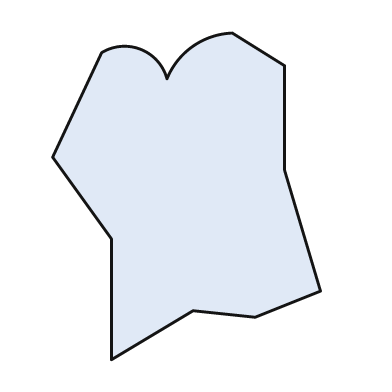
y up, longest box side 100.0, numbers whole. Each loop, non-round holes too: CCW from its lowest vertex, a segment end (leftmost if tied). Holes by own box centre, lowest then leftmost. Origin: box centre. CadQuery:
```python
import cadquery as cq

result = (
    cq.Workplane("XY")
    .moveTo(-23.0, -50.0)
    .lineTo(2.0, -35.0)
    .lineTo(21.0, -37.0)
    .lineTo(41.0, -29.0)
    .lineTo(30.0, 8.0)
    .lineTo(30.0, 40.0)
    .lineTo(14.0, 50.0)
    .threePointArc((2.0, 46.0), (-6.0, 36.0))
    .threePointArc((-14.0, 45.0), (-26.0, 44.0))
    .lineTo(-41.0, 12.0)
    .lineTo(-23.0, -13.0)
    .close()
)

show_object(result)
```